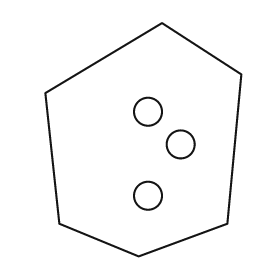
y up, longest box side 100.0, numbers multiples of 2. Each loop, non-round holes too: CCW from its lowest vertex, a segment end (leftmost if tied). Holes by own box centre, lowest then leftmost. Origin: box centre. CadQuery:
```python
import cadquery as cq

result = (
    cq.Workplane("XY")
    .moveTo(-2.0, -50.0)
    .lineTo(36.0, -36.0)
    .lineTo(42.0, 28.0)
    .lineTo(8.0, 50.0)
    .lineTo(-42.0, 20.0)
    .lineTo(-36.0, -36.0)
    .close()
    .moveTo(2.0, -24.0)
    .circle(6.0)
    .moveTo(16.0, -2.0)
    .circle(6.0)
    .moveTo(2.0, 12.0)
    .circle(6.0)
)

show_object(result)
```